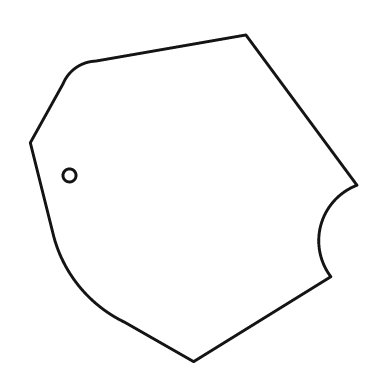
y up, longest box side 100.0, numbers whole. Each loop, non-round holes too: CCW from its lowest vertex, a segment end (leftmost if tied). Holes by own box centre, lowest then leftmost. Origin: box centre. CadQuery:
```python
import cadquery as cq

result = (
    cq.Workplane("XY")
    .moveTo(0.0, -50.0)
    .lineTo(42.0, -24.0)
    .threePointArc((39.0, -8.0), (50.0, 4.0))
    .lineTo(16.0, 50.0)
    .lineTo(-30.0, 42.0)
    .threePointArc((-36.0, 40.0), (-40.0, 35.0))
    .lineTo(-50.0, 17.0)
    .lineTo(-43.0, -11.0)
    .threePointArc((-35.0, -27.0), (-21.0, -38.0))
    .close()
    .moveTo(-38.0, 7.0)
    .circle(2.0)
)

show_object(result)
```